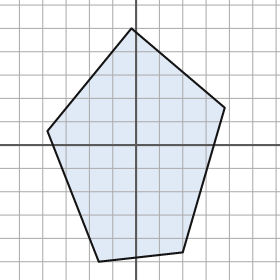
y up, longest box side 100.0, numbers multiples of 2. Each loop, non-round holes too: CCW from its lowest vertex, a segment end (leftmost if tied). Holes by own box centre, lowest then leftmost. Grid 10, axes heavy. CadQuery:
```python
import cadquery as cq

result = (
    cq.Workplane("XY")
    .moveTo(-16.0, -50.0)
    .lineTo(20.0, -46.0)
    .lineTo(38.0, 16.0)
    .lineTo(-2.0, 50.0)
    .lineTo(-38.0, 6.0)
    .close()
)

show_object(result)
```